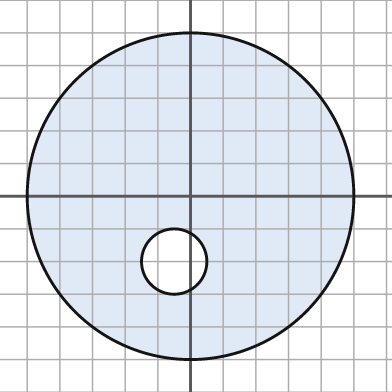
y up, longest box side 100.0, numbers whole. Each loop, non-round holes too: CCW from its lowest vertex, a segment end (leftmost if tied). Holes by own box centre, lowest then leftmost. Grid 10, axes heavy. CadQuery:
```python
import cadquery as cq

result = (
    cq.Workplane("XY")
    .moveTo(0.0, 0.0)
    .circle(50.0)
    .moveTo(-5.0, -20.0)
    .circle(10.0)
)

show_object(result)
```